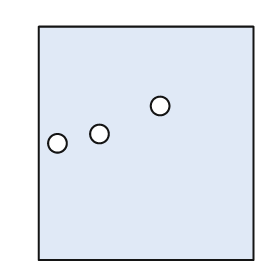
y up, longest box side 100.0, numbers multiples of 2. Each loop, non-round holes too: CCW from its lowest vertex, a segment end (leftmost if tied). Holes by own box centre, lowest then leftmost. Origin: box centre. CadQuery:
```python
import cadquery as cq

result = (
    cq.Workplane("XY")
    .moveTo(-46.0, -50.0)
    .lineTo(46.0, -50.0)
    .lineTo(46.0, 50.0)
    .lineTo(-46.0, 50.0)
    .close()
    .moveTo(-38.0, 0.0)
    .circle(4.0)
    .moveTo(-20.0, 4.0)
    .circle(4.0)
    .moveTo(6.0, 16.0)
    .circle(4.0)
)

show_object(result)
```